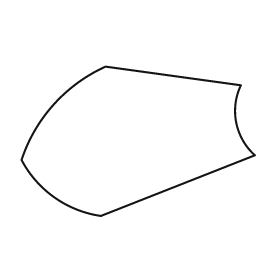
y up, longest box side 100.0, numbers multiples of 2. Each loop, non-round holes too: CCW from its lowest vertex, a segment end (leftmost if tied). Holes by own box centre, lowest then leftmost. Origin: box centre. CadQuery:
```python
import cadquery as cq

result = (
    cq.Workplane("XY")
    .moveTo(-16.0, -32.0)
    .lineTo(50.0, -6.0)
    .threePointArc((42.0, 8.0), (44.0, 24.0))
    .lineTo(-14.0, 32.0)
    .threePointArc((-36.0, 16.0), (-50.0, -8.0))
    .threePointArc((-36.0, -24.0), (-16.0, -32.0))
    .close()
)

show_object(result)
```